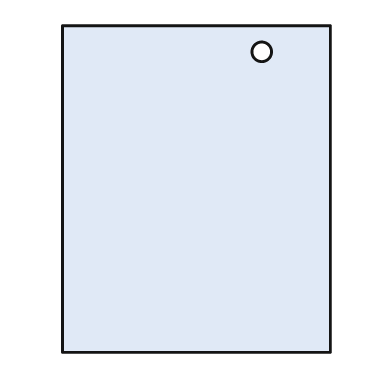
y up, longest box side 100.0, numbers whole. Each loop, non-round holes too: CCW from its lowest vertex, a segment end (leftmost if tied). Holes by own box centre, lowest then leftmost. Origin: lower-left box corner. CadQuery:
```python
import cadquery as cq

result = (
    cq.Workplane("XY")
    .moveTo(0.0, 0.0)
    .lineTo(82.0, 0.0)
    .lineTo(82.0, 100.0)
    .lineTo(0.0, 100.0)
    .close()
    .moveTo(61.0, 92.0)
    .circle(3.0)
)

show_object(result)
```